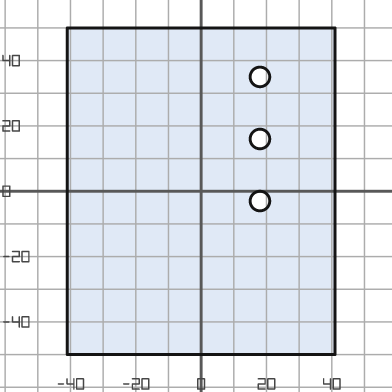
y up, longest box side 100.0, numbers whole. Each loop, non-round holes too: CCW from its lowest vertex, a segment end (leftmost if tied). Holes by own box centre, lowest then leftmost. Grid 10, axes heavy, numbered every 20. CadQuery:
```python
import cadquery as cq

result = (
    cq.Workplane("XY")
    .moveTo(-41.0, -50.0)
    .lineTo(41.0, -50.0)
    .lineTo(41.0, 50.0)
    .lineTo(-41.0, 50.0)
    .close()
    .moveTo(18.0, -3.0)
    .circle(3.0)
    .moveTo(18.0, 16.0)
    .circle(3.0)
    .moveTo(18.0, 35.0)
    .circle(3.0)
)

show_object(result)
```